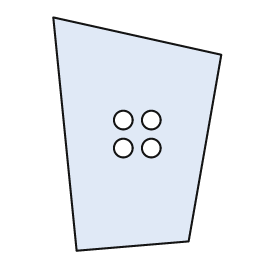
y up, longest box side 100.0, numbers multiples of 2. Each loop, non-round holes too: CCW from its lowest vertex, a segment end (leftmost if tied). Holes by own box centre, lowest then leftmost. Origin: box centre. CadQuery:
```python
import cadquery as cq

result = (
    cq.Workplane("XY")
    .moveTo(-26.0, -50.0)
    .lineTo(22.0, -46.0)
    .lineTo(36.0, 34.0)
    .lineTo(-36.0, 50.0)
    .close()
    .moveTo(-6.0, -6.0)
    .circle(4.0)
    .moveTo(6.0, -6.0)
    .circle(4.0)
    .moveTo(-6.0, 6.0)
    .circle(4.0)
    .moveTo(6.0, 6.0)
    .circle(4.0)
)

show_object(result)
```